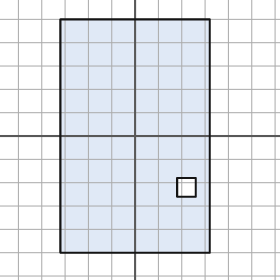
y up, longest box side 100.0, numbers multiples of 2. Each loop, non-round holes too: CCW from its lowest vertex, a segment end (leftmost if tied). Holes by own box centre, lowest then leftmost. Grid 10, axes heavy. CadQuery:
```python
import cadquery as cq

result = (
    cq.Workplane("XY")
    .moveTo(-32.0, -50.0)
    .lineTo(32.0, -50.0)
    .lineTo(32.0, 50.0)
    .lineTo(-32.0, 50.0)
    .close()
    .moveTo(18.0, -26.0)
    .lineTo(26.0, -26.0)
    .lineTo(26.0, -18.0)
    .lineTo(18.0, -18.0)
    .close()
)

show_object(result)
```